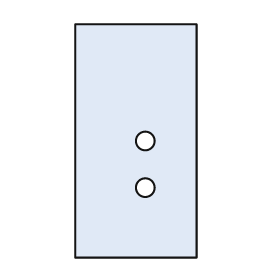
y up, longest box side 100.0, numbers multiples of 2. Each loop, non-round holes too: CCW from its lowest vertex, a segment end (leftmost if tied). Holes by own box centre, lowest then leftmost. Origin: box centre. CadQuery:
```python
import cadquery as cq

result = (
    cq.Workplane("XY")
    .moveTo(-26.0, -50.0)
    .lineTo(26.0, -50.0)
    .lineTo(26.0, 50.0)
    .lineTo(-26.0, 50.0)
    .close()
    .moveTo(4.0, -20.0)
    .circle(4.0)
    .moveTo(4.0, 0.0)
    .circle(4.0)
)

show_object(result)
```